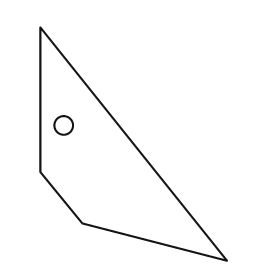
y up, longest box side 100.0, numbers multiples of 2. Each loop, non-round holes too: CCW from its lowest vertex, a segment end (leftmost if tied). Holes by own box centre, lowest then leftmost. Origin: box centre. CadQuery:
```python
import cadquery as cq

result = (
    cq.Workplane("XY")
    .moveTo(40.0, -50.0)
    .lineTo(-40.0, 50.0)
    .lineTo(-40.0, -12.0)
    .lineTo(-22.0, -34.0)
    .close()
    .moveTo(-30.0, 8.0)
    .circle(4.0)
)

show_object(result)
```